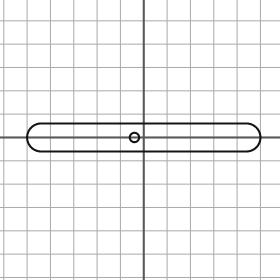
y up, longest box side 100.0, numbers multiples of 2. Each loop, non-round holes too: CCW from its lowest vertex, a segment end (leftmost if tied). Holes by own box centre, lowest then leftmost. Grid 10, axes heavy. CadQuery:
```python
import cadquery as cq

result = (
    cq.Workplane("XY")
    .moveTo(-44.0, -6.0)
    .lineTo(44.0, -6.0)
    .threePointArc((50.0, 0.0), (44.0, 6.0))
    .lineTo(-44.0, 6.0)
    .threePointArc((-50.0, 0.0), (-44.0, -6.0))
    .close()
    .moveTo(-4.0, 0.0)
    .circle(2.0)
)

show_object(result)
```